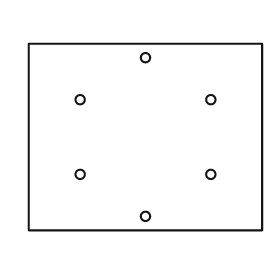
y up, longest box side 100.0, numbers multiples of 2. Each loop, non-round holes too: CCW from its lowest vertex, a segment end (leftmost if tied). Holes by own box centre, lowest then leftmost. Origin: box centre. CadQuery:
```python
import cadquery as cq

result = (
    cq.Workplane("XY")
    .moveTo(-50.0, -40.0)
    .lineTo(50.0, -40.0)
    .lineTo(50.0, 40.0)
    .lineTo(-50.0, 40.0)
    .close()
    .moveTo(0.0, -34.0)
    .circle(2.0)
    .moveTo(-28.0, -16.0)
    .circle(2.0)
    .moveTo(28.0, -16.0)
    .circle(2.0)
    .moveTo(-28.0, 16.0)
    .circle(2.0)
    .moveTo(28.0, 16.0)
    .circle(2.0)
    .moveTo(0.0, 34.0)
    .circle(2.0)
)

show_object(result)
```